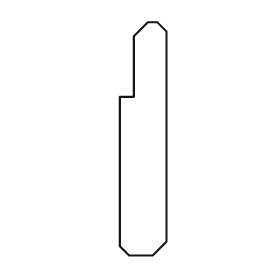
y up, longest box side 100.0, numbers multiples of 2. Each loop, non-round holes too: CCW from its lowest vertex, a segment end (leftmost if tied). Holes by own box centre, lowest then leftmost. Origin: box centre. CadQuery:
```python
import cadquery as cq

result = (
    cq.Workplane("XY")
    .moveTo(-6.0, -50.0)
    .lineTo(4.0, -50.0)
    .lineTo(10.0, -44.0)
    .lineTo(10.0, 46.0)
    .lineTo(6.0, 50.0)
    .lineTo(2.0, 50.0)
    .lineTo(-4.0, 44.0)
    .lineTo(-4.0, 18.0)
    .lineTo(-10.0, 18.0)
    .lineTo(-10.0, -46.0)
    .close()
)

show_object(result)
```